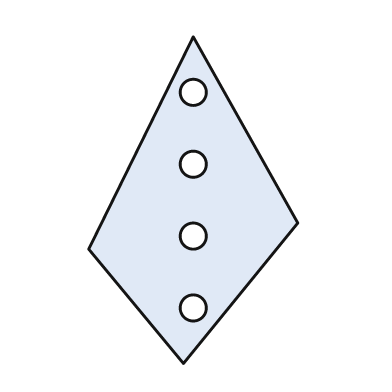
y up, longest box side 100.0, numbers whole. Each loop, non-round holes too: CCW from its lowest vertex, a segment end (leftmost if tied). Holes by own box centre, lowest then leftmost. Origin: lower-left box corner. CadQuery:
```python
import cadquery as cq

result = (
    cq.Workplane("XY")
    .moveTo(29.0, 0.0)
    .lineTo(64.0, 43.0)
    .lineTo(32.0, 100.0)
    .lineTo(0.0, 35.0)
    .close()
    .moveTo(32.0, 17.0)
    .circle(4.0)
    .moveTo(32.0, 39.0)
    .circle(4.0)
    .moveTo(32.0, 61.0)
    .circle(4.0)
    .moveTo(32.0, 83.0)
    .circle(4.0)
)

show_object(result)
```